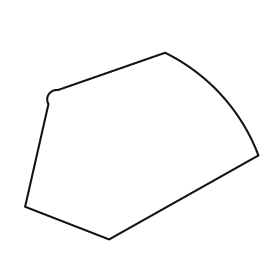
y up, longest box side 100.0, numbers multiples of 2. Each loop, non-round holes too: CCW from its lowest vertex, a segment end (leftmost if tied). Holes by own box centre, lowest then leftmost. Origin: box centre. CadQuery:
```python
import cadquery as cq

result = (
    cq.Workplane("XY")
    .moveTo(-14.0, -40.0)
    .lineTo(50.0, -4.0)
    .threePointArc((34.0, 22.0), (10.0, 40.0))
    .lineTo(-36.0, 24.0)
    .threePointArc((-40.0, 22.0), (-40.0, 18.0))
    .lineTo(-50.0, -26.0)
    .close()
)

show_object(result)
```